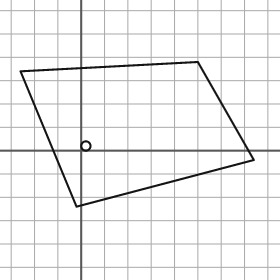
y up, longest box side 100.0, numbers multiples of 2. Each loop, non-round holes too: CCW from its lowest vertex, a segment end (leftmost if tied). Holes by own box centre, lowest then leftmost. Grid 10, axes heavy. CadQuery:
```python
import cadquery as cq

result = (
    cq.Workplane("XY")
    .moveTo(-2.0, -24.0)
    .lineTo(74.0, -4.0)
    .lineTo(50.0, 38.0)
    .lineTo(-26.0, 34.0)
    .close()
    .moveTo(2.0, 2.0)
    .circle(2.0)
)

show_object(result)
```